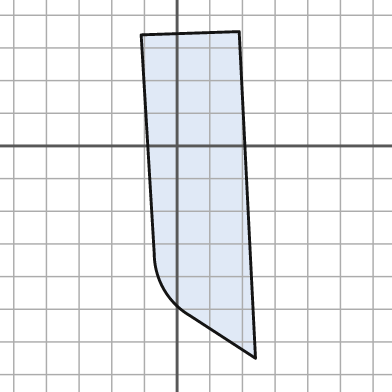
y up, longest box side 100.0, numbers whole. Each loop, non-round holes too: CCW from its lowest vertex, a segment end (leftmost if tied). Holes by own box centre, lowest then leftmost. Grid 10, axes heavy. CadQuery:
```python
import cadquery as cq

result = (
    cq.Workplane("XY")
    .moveTo(24.0, -65.0)
    .lineTo(19.0, 35.0)
    .lineTo(-11.0, 34.0)
    .lineTo(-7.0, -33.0)
    .threePointArc((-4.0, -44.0), (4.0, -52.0))
    .close()
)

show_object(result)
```